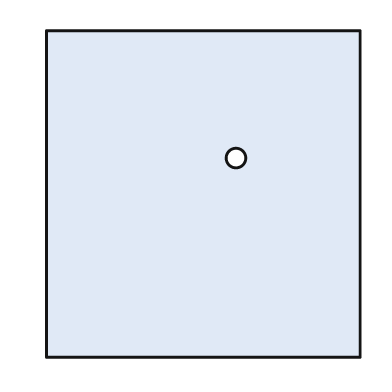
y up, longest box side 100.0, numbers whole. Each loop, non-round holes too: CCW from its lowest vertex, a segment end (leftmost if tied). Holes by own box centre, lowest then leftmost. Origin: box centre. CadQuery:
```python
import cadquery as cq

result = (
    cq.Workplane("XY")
    .moveTo(-48.0, -50.0)
    .lineTo(48.0, -50.0)
    .lineTo(48.0, 50.0)
    .lineTo(-48.0, 50.0)
    .close()
    .moveTo(10.0, 11.0)
    .circle(3.0)
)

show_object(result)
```